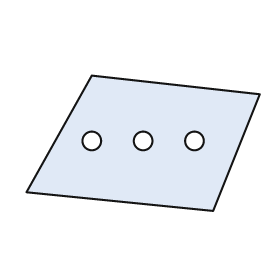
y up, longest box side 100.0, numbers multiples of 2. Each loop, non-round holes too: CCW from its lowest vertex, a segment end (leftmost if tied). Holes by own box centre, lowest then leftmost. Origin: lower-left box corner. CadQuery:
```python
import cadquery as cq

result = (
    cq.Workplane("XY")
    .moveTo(80.0, 0.0)
    .lineTo(100.0, 50.0)
    .lineTo(28.0, 58.0)
    .lineTo(0.0, 8.0)
    .close()
    .moveTo(28.0, 30.0)
    .circle(4.0)
    .moveTo(50.0, 30.0)
    .circle(4.0)
    .moveTo(72.0, 30.0)
    .circle(4.0)
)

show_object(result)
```